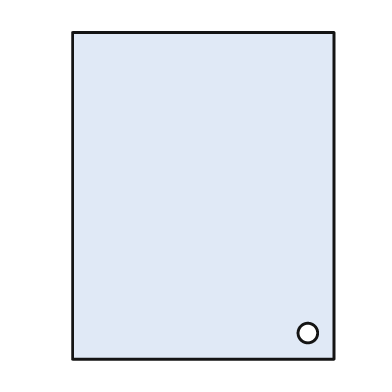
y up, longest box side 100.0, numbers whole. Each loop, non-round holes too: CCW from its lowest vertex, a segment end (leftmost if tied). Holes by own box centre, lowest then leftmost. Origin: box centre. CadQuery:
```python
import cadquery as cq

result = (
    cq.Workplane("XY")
    .moveTo(-40.0, -50.0)
    .lineTo(40.0, -50.0)
    .lineTo(40.0, 50.0)
    .lineTo(-40.0, 50.0)
    .close()
    .moveTo(32.0, -42.0)
    .circle(3.0)
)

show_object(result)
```